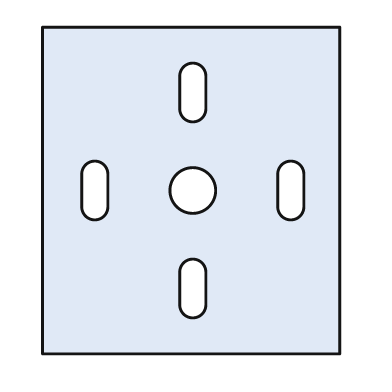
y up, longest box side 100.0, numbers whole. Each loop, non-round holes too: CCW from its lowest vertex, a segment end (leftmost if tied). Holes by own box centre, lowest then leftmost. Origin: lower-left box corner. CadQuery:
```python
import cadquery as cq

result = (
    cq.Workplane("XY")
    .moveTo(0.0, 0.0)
    .lineTo(91.0, 0.0)
    .lineTo(91.0, 100.0)
    .lineTo(0.0, 100.0)
    .close()
    .moveTo(42.0, 15.0)
    .threePointArc((46.0, 11.0), (50.0, 15.0))
    .lineTo(50.0, 25.0)
    .threePointArc((46.0, 29.0), (42.0, 25.0))
    .close()
    .moveTo(12.0, 45.0)
    .threePointArc((16.0, 41.0), (20.0, 45.0))
    .lineTo(20.0, 55.0)
    .threePointArc((16.0, 59.0), (12.0, 55.0))
    .close()
    .moveTo(46.0, 50.0)
    .circle(7.0)
    .moveTo(72.0, 45.0)
    .threePointArc((76.0, 41.0), (80.0, 45.0))
    .lineTo(80.0, 55.0)
    .threePointArc((76.0, 59.0), (72.0, 55.0))
    .close()
    .moveTo(42.0, 75.0)
    .threePointArc((46.0, 71.0), (50.0, 75.0))
    .lineTo(50.0, 85.0)
    .threePointArc((46.0, 89.0), (42.0, 85.0))
    .close()
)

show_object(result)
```